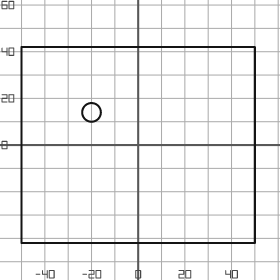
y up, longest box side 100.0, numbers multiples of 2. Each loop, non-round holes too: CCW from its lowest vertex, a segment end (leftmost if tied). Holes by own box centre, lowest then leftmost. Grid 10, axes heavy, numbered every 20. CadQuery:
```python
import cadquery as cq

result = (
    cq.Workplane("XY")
    .moveTo(-50.0, -42.0)
    .lineTo(50.0, -42.0)
    .lineTo(50.0, 42.0)
    .lineTo(-50.0, 42.0)
    .close()
    .moveTo(-20.0, 14.0)
    .circle(4.0)
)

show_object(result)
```